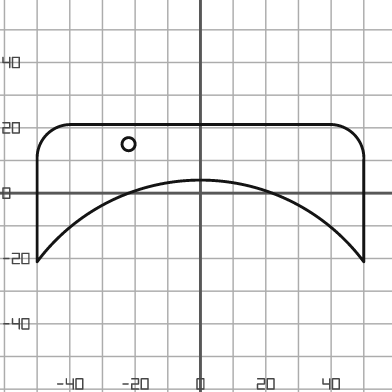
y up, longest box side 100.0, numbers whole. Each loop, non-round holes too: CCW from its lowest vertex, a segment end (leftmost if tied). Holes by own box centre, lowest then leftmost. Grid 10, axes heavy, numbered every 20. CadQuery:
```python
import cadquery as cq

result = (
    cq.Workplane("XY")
    .moveTo(-50.0, -21.0)
    .threePointArc((0.0, 4.0), (50.0, -21.0))
    .lineTo(50.0, 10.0)
    .threePointArc((47.0, 18.0), (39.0, 21.0))
    .lineTo(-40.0, 21.0)
    .threePointArc((-47.0, 18.0), (-50.0, 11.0))
    .close()
    .moveTo(-22.0, 15.0)
    .circle(2.0)
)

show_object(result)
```